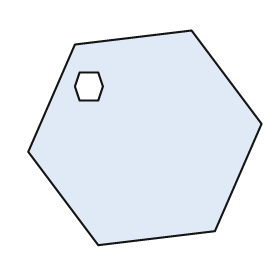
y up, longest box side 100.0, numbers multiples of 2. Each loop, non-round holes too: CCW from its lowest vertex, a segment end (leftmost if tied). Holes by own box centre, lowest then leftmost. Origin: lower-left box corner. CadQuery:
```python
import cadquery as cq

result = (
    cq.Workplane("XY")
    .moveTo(30.0, 0.0)
    .lineTo(80.0, 6.0)
    .lineTo(100.0, 52.0)
    .lineTo(70.0, 92.0)
    .lineTo(20.0, 86.0)
    .lineTo(0.0, 40.0)
    .close()
    .moveTo(22.0, 62.0)
    .lineTo(30.0, 62.0)
    .lineTo(32.0, 68.0)
    .lineTo(30.0, 74.0)
    .lineTo(22.0, 74.0)
    .lineTo(20.0, 68.0)
    .close()
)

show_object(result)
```